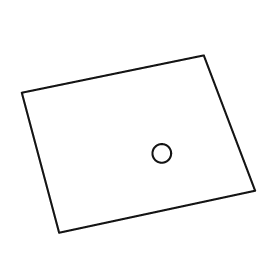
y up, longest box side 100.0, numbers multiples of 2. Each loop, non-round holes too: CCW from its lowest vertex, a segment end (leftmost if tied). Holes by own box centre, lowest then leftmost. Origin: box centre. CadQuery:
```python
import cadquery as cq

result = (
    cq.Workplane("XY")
    .moveTo(-34.0, -38.0)
    .lineTo(50.0, -20.0)
    .lineTo(28.0, 38.0)
    .lineTo(-50.0, 22.0)
    .close()
    .moveTo(10.0, -4.0)
    .circle(4.0)
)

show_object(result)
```